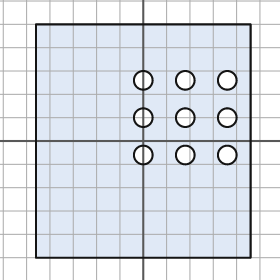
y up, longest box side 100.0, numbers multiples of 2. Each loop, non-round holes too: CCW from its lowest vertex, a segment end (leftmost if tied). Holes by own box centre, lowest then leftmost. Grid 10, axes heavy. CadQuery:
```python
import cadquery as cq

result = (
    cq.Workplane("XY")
    .moveTo(-46.0, -50.0)
    .lineTo(46.0, -50.0)
    .lineTo(46.0, 50.0)
    .lineTo(-46.0, 50.0)
    .close()
    .moveTo(0.0, -6.0)
    .circle(4.0)
    .moveTo(18.0, -6.0)
    .circle(4.0)
    .moveTo(36.0, -6.0)
    .circle(4.0)
    .moveTo(0.0, 10.0)
    .circle(4.0)
    .moveTo(18.0, 10.0)
    .circle(4.0)
    .moveTo(36.0, 10.0)
    .circle(4.0)
    .moveTo(0.0, 26.0)
    .circle(4.0)
    .moveTo(18.0, 26.0)
    .circle(4.0)
    .moveTo(36.0, 26.0)
    .circle(4.0)
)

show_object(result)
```